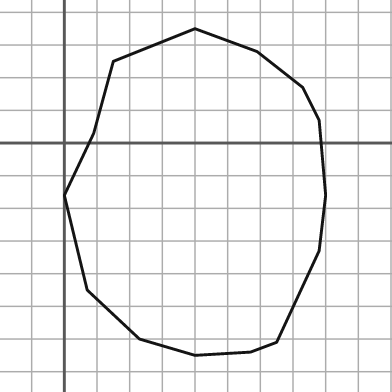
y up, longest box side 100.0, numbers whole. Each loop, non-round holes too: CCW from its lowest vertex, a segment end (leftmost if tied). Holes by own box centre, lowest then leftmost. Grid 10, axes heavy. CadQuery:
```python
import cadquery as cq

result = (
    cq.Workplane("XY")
    .moveTo(40.0, -65.0)
    .lineTo(57.0, -64.0)
    .lineTo(65.0, -61.0)
    .lineTo(78.0, -33.0)
    .lineTo(80.0, -16.0)
    .lineTo(78.0, 7.0)
    .lineTo(73.0, 17.0)
    .lineTo(59.0, 28.0)
    .lineTo(40.0, 35.0)
    .lineTo(15.0, 25.0)
    .lineTo(9.0, 3.0)
    .lineTo(0.0, -16.0)
    .lineTo(7.0, -45.0)
    .lineTo(23.0, -60.0)
    .close()
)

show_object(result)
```